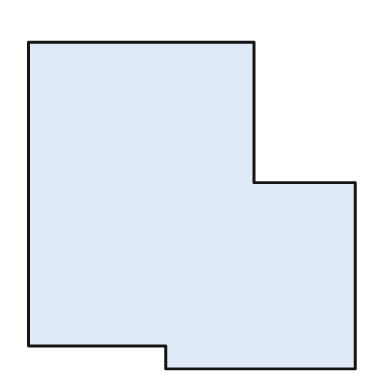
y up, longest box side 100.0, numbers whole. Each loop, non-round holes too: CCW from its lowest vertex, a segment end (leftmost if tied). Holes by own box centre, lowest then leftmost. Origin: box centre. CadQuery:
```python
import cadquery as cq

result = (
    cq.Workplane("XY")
    .moveTo(-8.0, -50.0)
    .lineTo(50.0, -50.0)
    .lineTo(50.0, 7.0)
    .lineTo(19.0, 7.0)
    .lineTo(19.0, 50.0)
    .lineTo(-50.0, 50.0)
    .lineTo(-50.0, -43.0)
    .lineTo(-8.0, -43.0)
    .close()
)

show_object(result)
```